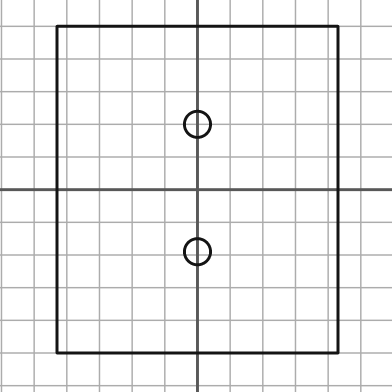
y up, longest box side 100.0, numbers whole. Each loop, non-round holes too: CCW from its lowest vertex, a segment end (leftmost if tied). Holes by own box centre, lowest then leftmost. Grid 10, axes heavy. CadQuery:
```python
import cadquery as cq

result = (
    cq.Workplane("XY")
    .moveTo(-43.0, -50.0)
    .lineTo(43.0, -50.0)
    .lineTo(43.0, 50.0)
    .lineTo(-43.0, 50.0)
    .close()
    .moveTo(0.0, -19.0)
    .circle(4.0)
    .moveTo(0.0, 20.0)
    .circle(4.0)
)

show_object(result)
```